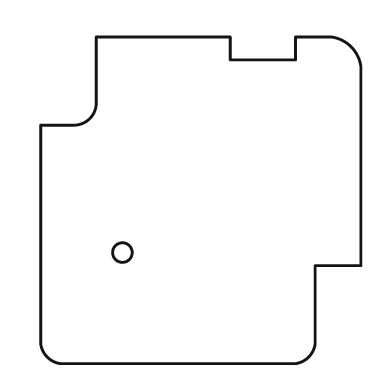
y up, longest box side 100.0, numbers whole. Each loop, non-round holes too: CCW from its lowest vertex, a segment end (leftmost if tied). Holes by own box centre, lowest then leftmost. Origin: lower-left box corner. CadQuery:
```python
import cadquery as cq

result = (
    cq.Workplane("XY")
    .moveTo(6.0, 0.0)
    .lineTo(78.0, 0.0)
    .threePointArc((82.0, 2.0), (84.0, 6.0))
    .lineTo(84.0, 30.0)
    .lineTo(98.0, 30.0)
    .lineTo(98.0, 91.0)
    .threePointArc((95.0, 97.0), (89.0, 100.0))
    .lineTo(78.0, 100.0)
    .lineTo(78.0, 93.0)
    .lineTo(58.0, 93.0)
    .lineTo(58.0, 100.0)
    .lineTo(17.0, 100.0)
    .lineTo(17.0, 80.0)
    .threePointArc((15.0, 75.0), (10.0, 73.0))
    .lineTo(0.0, 73.0)
    .lineTo(0.0, 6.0)
    .threePointArc((2.0, 2.0), (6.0, 0.0))
    .close()
    .moveTo(25.0, 34.0)
    .circle(3.0)
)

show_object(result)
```